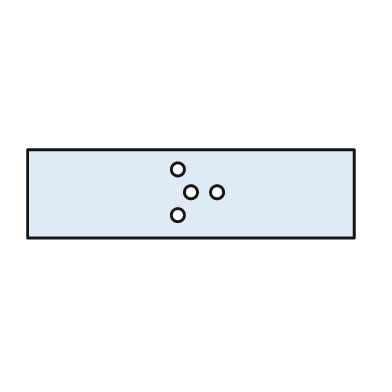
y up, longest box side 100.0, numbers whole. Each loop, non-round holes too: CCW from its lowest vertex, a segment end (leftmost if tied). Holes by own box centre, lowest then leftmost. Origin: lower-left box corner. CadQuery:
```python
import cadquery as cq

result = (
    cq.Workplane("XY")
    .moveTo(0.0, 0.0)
    .lineTo(100.0, 0.0)
    .lineTo(100.0, 27.0)
    .lineTo(0.0, 27.0)
    .close()
    .moveTo(46.0, 7.0)
    .circle(2.0)
    .moveTo(50.0, 14.0)
    .circle(2.0)
    .moveTo(58.0, 14.0)
    .circle(2.0)
    .moveTo(46.0, 21.0)
    .circle(2.0)
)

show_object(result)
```